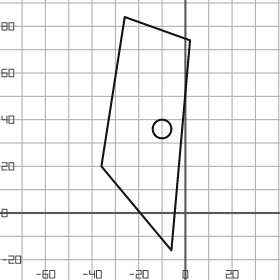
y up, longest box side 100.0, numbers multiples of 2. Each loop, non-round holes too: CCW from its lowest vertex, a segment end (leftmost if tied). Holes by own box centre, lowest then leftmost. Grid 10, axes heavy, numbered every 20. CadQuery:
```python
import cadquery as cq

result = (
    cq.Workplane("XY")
    .moveTo(-6.0, -16.0)
    .lineTo(2.0, 74.0)
    .lineTo(-26.0, 84.0)
    .lineTo(-36.0, 20.0)
    .close()
    .moveTo(-10.0, 36.0)
    .circle(4.0)
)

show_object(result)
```